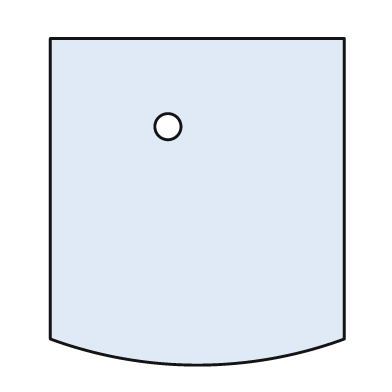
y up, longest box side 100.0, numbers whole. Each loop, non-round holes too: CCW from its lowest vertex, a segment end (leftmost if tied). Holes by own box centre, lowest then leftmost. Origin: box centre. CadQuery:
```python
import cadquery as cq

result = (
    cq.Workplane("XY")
    .moveTo(-45.0, -42.0)
    .threePointArc((0.0, -50.0), (45.0, -42.0))
    .lineTo(45.0, 50.0)
    .lineTo(-45.0, 50.0)
    .close()
    .moveTo(-9.0, 23.0)
    .circle(4.0)
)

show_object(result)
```